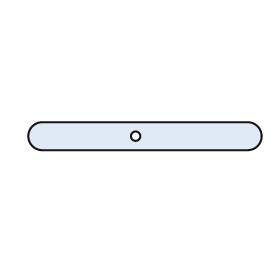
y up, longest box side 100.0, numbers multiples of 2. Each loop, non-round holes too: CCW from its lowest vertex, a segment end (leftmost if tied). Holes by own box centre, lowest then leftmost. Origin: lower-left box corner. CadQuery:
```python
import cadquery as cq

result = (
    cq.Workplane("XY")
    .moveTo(6.0, 0.0)
    .lineTo(94.0, 0.0)
    .threePointArc((100.0, 6.0), (94.0, 12.0))
    .lineTo(6.0, 12.0)
    .threePointArc((0.0, 6.0), (6.0, 0.0))
    .close()
    .moveTo(46.0, 6.0)
    .circle(2.0)
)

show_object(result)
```